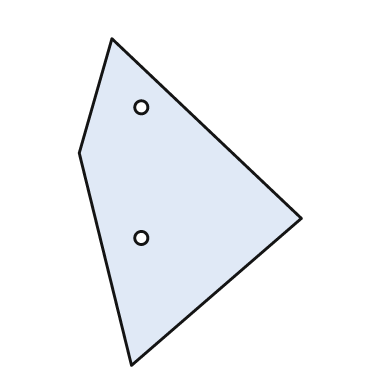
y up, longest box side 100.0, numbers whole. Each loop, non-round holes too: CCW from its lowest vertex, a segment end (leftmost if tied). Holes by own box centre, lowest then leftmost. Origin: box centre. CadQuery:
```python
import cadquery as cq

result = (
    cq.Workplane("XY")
    .moveTo(-18.0, -50.0)
    .lineTo(34.0, -5.0)
    .lineTo(-24.0, 50.0)
    .lineTo(-34.0, 15.0)
    .close()
    .moveTo(-15.0, -11.0)
    .circle(2.0)
    .moveTo(-15.0, 29.0)
    .circle(2.0)
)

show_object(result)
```